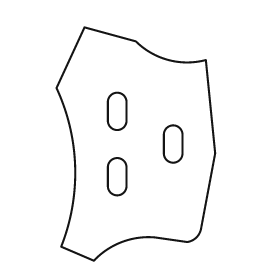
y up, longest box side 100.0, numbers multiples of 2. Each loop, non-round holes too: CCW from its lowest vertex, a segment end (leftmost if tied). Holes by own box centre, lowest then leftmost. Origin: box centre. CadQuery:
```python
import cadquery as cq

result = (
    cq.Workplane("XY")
    .moveTo(-18.0, -50.0)
    .threePointArc((-6.0, -42.0), (8.0, -40.0))
    .lineTo(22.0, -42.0)
    .threePointArc((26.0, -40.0), (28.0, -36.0))
    .lineTo(34.0, -4.0)
    .lineTo(30.0, 36.0)
    .threePointArc((14.0, 36.0), (0.0, 44.0))
    .lineTo(-22.0, 50.0)
    .lineTo(-34.0, 24.0)
    .threePointArc((-26.0, -10.0), (-32.0, -44.0))
    .close()
    .moveTo(-12.0, -18.0)
    .threePointArc((-8.0, -22.0), (-4.0, -18.0))
    .lineTo(-4.0, -10.0)
    .threePointArc((-8.0, -6.0), (-12.0, -10.0))
    .close()
    .moveTo(12.0, -4.0)
    .threePointArc((16.0, -8.0), (20.0, -4.0))
    .lineTo(20.0, 4.0)
    .threePointArc((16.0, 8.0), (12.0, 4.0))
    .close()
    .moveTo(-12.0, 10.0)
    .threePointArc((-8.0, 6.0), (-4.0, 10.0))
    .lineTo(-4.0, 18.0)
    .threePointArc((-8.0, 22.0), (-12.0, 18.0))
    .close()
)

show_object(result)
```